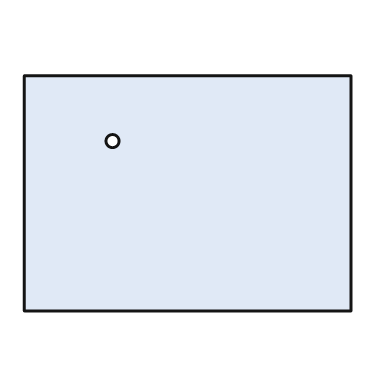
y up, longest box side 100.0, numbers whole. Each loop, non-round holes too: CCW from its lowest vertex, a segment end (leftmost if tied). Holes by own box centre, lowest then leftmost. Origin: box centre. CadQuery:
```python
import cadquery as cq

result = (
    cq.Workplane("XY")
    .moveTo(-50.0, -36.0)
    .lineTo(50.0, -36.0)
    .lineTo(50.0, 36.0)
    .lineTo(-50.0, 36.0)
    .close()
    .moveTo(-23.0, 16.0)
    .circle(2.0)
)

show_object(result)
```